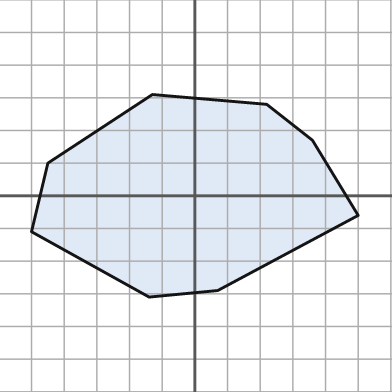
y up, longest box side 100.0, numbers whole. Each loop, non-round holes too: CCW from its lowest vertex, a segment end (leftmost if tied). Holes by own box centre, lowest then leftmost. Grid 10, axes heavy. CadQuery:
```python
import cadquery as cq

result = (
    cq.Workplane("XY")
    .moveTo(-14.0, -31.0)
    .lineTo(7.0, -29.0)
    .lineTo(50.0, -6.0)
    .lineTo(36.0, 17.0)
    .lineTo(22.0, 28.0)
    .lineTo(-13.0, 31.0)
    .lineTo(-45.0, 10.0)
    .lineTo(-50.0, -11.0)
    .close()
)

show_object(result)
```